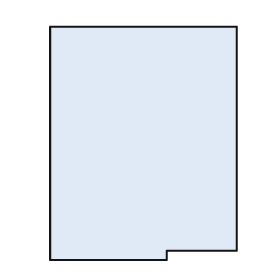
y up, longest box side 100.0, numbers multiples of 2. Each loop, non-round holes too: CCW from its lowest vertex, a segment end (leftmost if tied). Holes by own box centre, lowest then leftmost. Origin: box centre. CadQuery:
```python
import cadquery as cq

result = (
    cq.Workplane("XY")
    .moveTo(-40.0, -50.0)
    .lineTo(10.0, -50.0)
    .lineTo(10.0, -46.0)
    .lineTo(40.0, -46.0)
    .lineTo(40.0, 50.0)
    .lineTo(-40.0, 50.0)
    .close()
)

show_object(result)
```